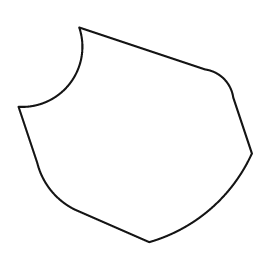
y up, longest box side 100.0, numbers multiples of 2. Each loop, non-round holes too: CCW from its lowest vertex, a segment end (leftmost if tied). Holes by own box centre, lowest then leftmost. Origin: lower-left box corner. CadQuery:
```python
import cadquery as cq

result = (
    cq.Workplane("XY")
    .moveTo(56.0, 0.0)
    .threePointArc((82.0, 14.0), (100.0, 38.0))
    .lineTo(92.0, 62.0)
    .threePointArc((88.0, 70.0), (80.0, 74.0))
    .lineTo(26.0, 92.0)
    .threePointArc((22.0, 68.0), (0.0, 58.0))
    .lineTo(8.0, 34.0)
    .threePointArc((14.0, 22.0), (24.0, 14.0))
    .close()
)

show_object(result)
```